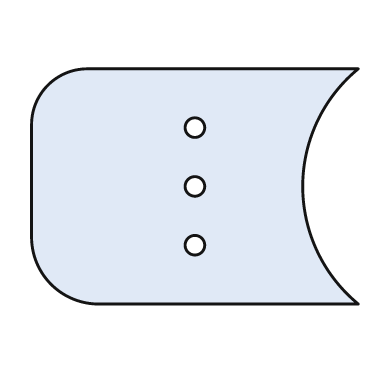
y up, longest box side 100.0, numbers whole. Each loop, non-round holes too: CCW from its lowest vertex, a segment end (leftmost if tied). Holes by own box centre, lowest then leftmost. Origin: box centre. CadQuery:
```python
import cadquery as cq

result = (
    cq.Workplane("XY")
    .moveTo(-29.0, -36.0)
    .lineTo(50.0, -36.0)
    .threePointArc((33.0, 0.0), (50.0, 36.0))
    .lineTo(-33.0, 36.0)
    .threePointArc((-45.0, 31.0), (-50.0, 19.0))
    .lineTo(-50.0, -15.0)
    .threePointArc((-44.0, -30.0), (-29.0, -36.0))
    .close()
    .moveTo(0.0, -18.0)
    .circle(3.0)
    .moveTo(0.0, 0.0)
    .circle(3.0)
    .moveTo(0.0, 18.0)
    .circle(3.0)
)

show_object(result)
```